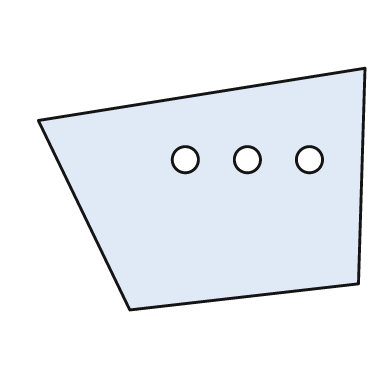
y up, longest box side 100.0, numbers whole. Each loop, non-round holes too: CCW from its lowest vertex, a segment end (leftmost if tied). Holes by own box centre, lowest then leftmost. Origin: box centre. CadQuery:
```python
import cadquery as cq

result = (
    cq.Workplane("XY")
    .moveTo(-22.0, -37.0)
    .lineTo(48.0, -29.0)
    .lineTo(50.0, 37.0)
    .lineTo(-50.0, 21.0)
    .close()
    .moveTo(-5.0, 9.0)
    .circle(4.0)
    .moveTo(14.0, 9.0)
    .circle(4.0)
    .moveTo(33.0, 9.0)
    .circle(4.0)
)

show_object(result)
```